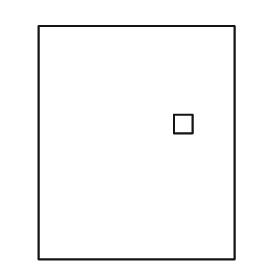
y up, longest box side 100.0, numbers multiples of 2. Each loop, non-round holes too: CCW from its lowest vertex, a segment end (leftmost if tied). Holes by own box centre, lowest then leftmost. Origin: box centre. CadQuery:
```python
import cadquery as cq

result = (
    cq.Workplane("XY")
    .moveTo(-42.0, -50.0)
    .lineTo(42.0, -50.0)
    .lineTo(42.0, 50.0)
    .lineTo(-42.0, 50.0)
    .close()
    .moveTo(16.0, 4.0)
    .lineTo(24.0, 4.0)
    .lineTo(24.0, 12.0)
    .lineTo(16.0, 12.0)
    .close()
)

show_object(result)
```